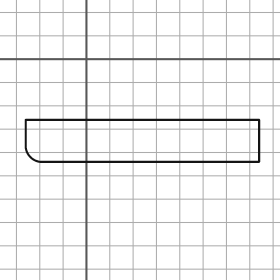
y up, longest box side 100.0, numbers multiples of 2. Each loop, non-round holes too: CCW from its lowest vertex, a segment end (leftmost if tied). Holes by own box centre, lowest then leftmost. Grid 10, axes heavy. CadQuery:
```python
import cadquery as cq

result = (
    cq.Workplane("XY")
    .moveTo(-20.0, -44.0)
    .lineTo(74.0, -44.0)
    .lineTo(74.0, -26.0)
    .lineTo(-26.0, -26.0)
    .lineTo(-26.0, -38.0)
    .threePointArc((-24.0, -42.0), (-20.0, -44.0))
    .close()
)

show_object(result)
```